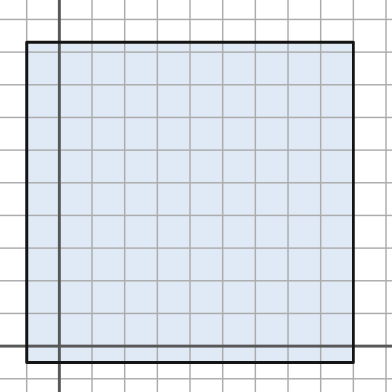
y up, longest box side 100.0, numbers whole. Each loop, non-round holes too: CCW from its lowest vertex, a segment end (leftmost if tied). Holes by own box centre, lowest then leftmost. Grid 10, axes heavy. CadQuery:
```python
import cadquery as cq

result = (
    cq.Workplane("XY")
    .moveTo(-10.0, -5.0)
    .lineTo(90.0, -5.0)
    .lineTo(90.0, 93.0)
    .lineTo(-10.0, 93.0)
    .close()
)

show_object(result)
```